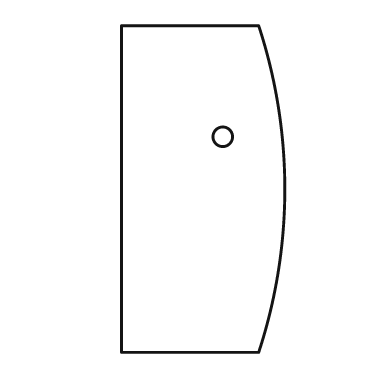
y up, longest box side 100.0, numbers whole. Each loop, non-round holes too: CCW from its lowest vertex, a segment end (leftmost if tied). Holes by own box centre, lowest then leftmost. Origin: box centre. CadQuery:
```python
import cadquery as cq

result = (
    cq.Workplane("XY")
    .moveTo(-25.0, -50.0)
    .lineTo(17.0, -50.0)
    .threePointArc((25.0, 0.0), (17.0, 50.0))
    .lineTo(-25.0, 50.0)
    .close()
    .moveTo(6.0, 16.0)
    .circle(3.0)
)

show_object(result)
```